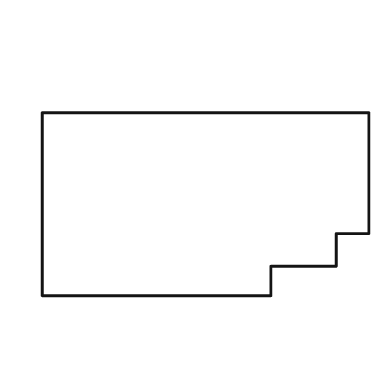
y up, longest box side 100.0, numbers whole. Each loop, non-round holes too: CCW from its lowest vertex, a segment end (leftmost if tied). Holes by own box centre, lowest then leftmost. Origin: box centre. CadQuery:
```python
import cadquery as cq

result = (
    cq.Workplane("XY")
    .moveTo(-50.0, -28.0)
    .lineTo(20.0, -28.0)
    .lineTo(20.0, -19.0)
    .lineTo(40.0, -19.0)
    .lineTo(40.0, -9.0)
    .lineTo(50.0, -9.0)
    .lineTo(50.0, 28.0)
    .lineTo(-50.0, 28.0)
    .close()
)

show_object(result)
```